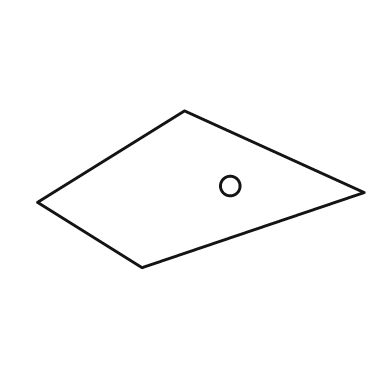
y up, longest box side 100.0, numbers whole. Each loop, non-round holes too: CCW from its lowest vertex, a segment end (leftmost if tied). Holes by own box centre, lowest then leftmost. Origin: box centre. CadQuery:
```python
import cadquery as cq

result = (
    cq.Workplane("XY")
    .moveTo(-18.0, -24.0)
    .lineTo(50.0, -1.0)
    .lineTo(-5.0, 24.0)
    .lineTo(-50.0, -4.0)
    .close()
    .moveTo(9.0, 1.0)
    .circle(3.0)
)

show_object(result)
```